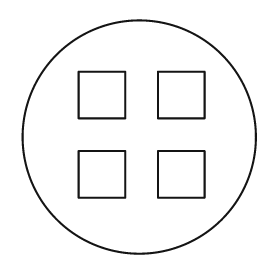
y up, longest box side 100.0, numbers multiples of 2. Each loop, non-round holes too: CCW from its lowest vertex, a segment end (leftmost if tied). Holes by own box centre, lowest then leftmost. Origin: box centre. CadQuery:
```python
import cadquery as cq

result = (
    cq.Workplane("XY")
    .moveTo(0.0, 0.0)
    .circle(50.0)
    .moveTo(-26.0, -26.0)
    .lineTo(-6.0, -26.0)
    .lineTo(-6.0, -6.0)
    .lineTo(-26.0, -6.0)
    .close()
    .moveTo(8.0, -26.0)
    .lineTo(28.0, -26.0)
    .lineTo(28.0, -6.0)
    .lineTo(8.0, -6.0)
    .close()
    .moveTo(-26.0, 8.0)
    .lineTo(-6.0, 8.0)
    .lineTo(-6.0, 28.0)
    .lineTo(-26.0, 28.0)
    .close()
    .moveTo(8.0, 8.0)
    .lineTo(28.0, 8.0)
    .lineTo(28.0, 28.0)
    .lineTo(8.0, 28.0)
    .close()
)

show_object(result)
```